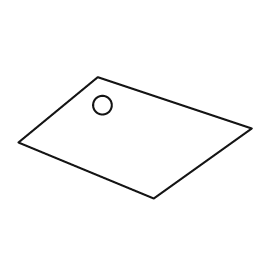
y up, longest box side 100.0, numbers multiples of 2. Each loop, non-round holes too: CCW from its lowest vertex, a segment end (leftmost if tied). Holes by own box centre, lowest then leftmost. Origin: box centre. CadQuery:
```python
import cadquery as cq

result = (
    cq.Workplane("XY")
    .moveTo(8.0, -26.0)
    .lineTo(50.0, 4.0)
    .lineTo(-16.0, 26.0)
    .lineTo(-50.0, -2.0)
    .close()
    .moveTo(-14.0, 14.0)
    .circle(4.0)
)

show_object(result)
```